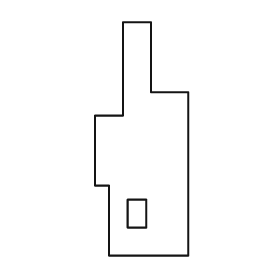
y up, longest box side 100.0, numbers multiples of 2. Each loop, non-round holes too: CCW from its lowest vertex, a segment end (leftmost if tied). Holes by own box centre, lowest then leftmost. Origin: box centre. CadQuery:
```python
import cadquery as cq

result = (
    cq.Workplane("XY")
    .moveTo(-14.0, -50.0)
    .lineTo(20.0, -50.0)
    .lineTo(20.0, 20.0)
    .lineTo(4.0, 20.0)
    .lineTo(4.0, 50.0)
    .lineTo(-8.0, 50.0)
    .lineTo(-8.0, 10.0)
    .lineTo(-20.0, 10.0)
    .lineTo(-20.0, -20.0)
    .lineTo(-14.0, -20.0)
    .close()
    .moveTo(-6.0, -38.0)
    .lineTo(2.0, -38.0)
    .lineTo(2.0, -26.0)
    .lineTo(-6.0, -26.0)
    .close()
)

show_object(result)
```